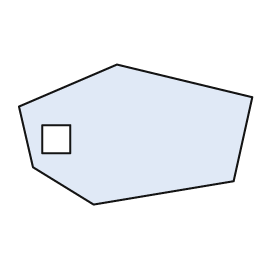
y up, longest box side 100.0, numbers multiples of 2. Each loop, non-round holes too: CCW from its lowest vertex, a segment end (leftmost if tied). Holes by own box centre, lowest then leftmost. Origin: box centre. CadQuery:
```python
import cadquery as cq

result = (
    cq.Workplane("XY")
    .moveTo(-18.0, -30.0)
    .lineTo(42.0, -20.0)
    .lineTo(50.0, 16.0)
    .lineTo(-8.0, 30.0)
    .lineTo(-50.0, 12.0)
    .lineTo(-44.0, -14.0)
    .close()
    .moveTo(-40.0, -8.0)
    .lineTo(-28.0, -8.0)
    .lineTo(-28.0, 4.0)
    .lineTo(-40.0, 4.0)
    .close()
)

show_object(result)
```